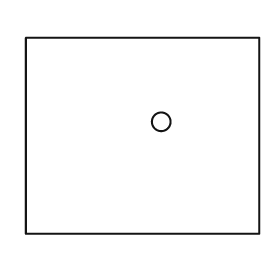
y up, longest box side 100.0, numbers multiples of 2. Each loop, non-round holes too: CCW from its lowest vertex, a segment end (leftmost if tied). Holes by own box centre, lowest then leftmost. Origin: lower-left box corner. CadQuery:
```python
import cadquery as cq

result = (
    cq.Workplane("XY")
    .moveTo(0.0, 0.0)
    .lineTo(100.0, 0.0)
    .lineTo(100.0, 84.0)
    .lineTo(0.0, 84.0)
    .close()
    .moveTo(58.0, 48.0)
    .circle(4.0)
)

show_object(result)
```